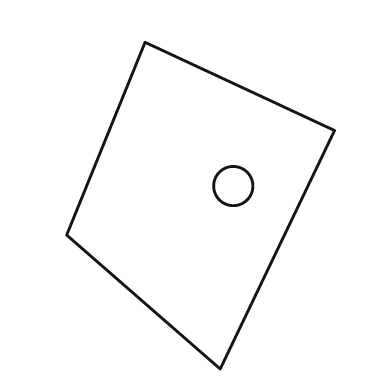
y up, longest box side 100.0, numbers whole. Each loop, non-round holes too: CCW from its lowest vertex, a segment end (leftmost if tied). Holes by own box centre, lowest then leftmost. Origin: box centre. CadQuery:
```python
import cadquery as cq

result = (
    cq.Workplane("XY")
    .moveTo(6.0, -50.0)
    .lineTo(41.0, 23.0)
    .lineTo(-17.0, 50.0)
    .lineTo(-41.0, -9.0)
    .close()
    .moveTo(10.0, 6.0)
    .circle(6.0)
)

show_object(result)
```